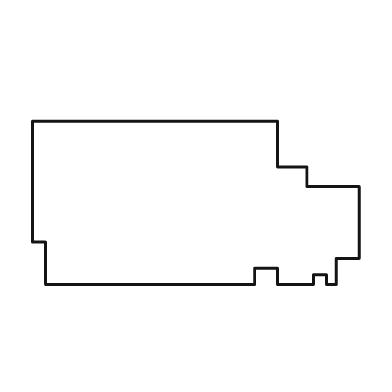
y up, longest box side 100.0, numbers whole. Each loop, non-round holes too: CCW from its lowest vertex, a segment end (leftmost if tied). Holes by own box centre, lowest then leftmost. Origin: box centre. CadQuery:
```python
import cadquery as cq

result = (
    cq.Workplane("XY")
    .moveTo(-46.0, -25.0)
    .lineTo(18.0, -25.0)
    .lineTo(18.0, -20.0)
    .lineTo(25.0, -20.0)
    .lineTo(25.0, -25.0)
    .lineTo(36.0, -25.0)
    .lineTo(36.0, -22.0)
    .lineTo(40.0, -22.0)
    .lineTo(40.0, -25.0)
    .lineTo(43.0, -25.0)
    .lineTo(43.0, -17.0)
    .lineTo(50.0, -17.0)
    .lineTo(50.0, 5.0)
    .lineTo(34.0, 5.0)
    .lineTo(34.0, 11.0)
    .lineTo(25.0, 11.0)
    .lineTo(25.0, 25.0)
    .lineTo(-50.0, 25.0)
    .lineTo(-50.0, -12.0)
    .lineTo(-46.0, -12.0)
    .close()
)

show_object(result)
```